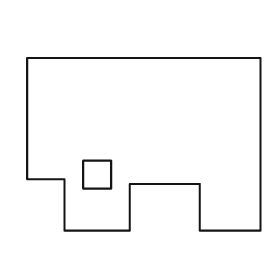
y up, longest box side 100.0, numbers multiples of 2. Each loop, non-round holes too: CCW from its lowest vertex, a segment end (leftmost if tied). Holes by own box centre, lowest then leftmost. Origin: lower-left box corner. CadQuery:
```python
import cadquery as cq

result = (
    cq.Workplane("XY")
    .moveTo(16.0, 0.0)
    .lineTo(44.0, 0.0)
    .lineTo(44.0, 20.0)
    .lineTo(74.0, 20.0)
    .lineTo(74.0, 0.0)
    .lineTo(100.0, 0.0)
    .lineTo(100.0, 74.0)
    .lineTo(0.0, 74.0)
    .lineTo(0.0, 22.0)
    .lineTo(16.0, 22.0)
    .close()
    .moveTo(24.0, 18.0)
    .lineTo(36.0, 18.0)
    .lineTo(36.0, 30.0)
    .lineTo(24.0, 30.0)
    .close()
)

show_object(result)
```